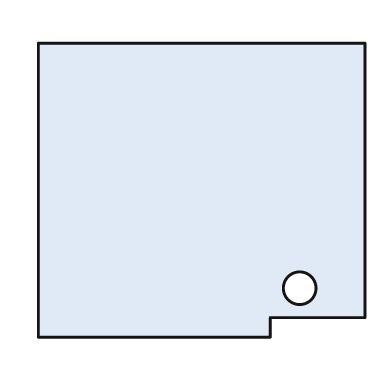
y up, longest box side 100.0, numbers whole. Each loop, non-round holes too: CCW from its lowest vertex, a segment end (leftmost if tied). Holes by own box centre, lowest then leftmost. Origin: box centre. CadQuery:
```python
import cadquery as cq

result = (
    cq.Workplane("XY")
    .moveTo(-50.0, -45.0)
    .lineTo(21.0, -45.0)
    .lineTo(21.0, -39.0)
    .lineTo(50.0, -39.0)
    .lineTo(50.0, 45.0)
    .lineTo(-50.0, 45.0)
    .close()
    .moveTo(30.0, -30.0)
    .circle(5.0)
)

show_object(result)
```